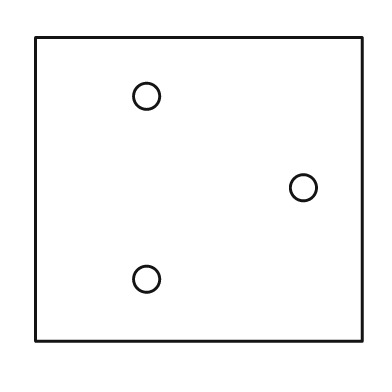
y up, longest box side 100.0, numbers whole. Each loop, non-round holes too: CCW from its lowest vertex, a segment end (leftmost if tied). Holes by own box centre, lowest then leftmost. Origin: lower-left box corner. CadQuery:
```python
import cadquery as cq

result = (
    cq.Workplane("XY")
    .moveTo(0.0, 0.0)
    .lineTo(100.0, 0.0)
    .lineTo(100.0, 93.0)
    .lineTo(0.0, 93.0)
    .close()
    .moveTo(34.0, 19.0)
    .circle(4.0)
    .moveTo(82.0, 47.0)
    .circle(4.0)
    .moveTo(34.0, 75.0)
    .circle(4.0)
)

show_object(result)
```